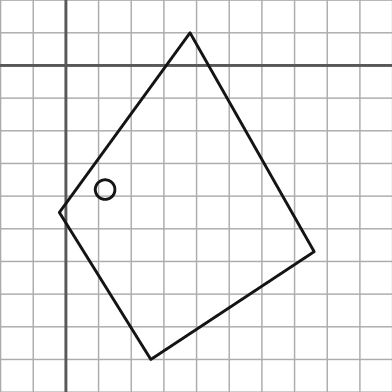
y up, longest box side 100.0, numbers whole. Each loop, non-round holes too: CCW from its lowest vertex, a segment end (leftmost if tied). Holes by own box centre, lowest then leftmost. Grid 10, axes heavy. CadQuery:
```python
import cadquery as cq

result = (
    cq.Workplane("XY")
    .moveTo(26.0, -90.0)
    .lineTo(76.0, -57.0)
    .lineTo(38.0, 10.0)
    .lineTo(-2.0, -45.0)
    .close()
    .moveTo(12.0, -38.0)
    .circle(3.0)
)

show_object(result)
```